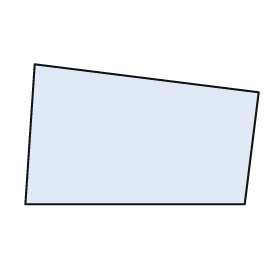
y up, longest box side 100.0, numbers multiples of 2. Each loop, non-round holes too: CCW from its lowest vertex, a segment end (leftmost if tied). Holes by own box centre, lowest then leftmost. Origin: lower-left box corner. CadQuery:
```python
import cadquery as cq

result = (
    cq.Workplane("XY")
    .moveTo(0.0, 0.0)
    .lineTo(94.0, 0.0)
    .lineTo(100.0, 48.0)
    .lineTo(4.0, 60.0)
    .close()
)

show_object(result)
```